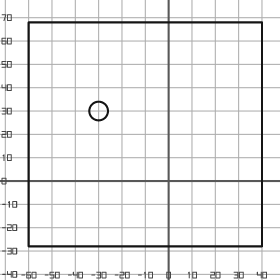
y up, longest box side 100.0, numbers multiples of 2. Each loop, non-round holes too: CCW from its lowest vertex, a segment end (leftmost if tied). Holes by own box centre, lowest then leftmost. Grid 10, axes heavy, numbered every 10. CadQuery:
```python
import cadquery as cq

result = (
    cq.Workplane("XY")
    .moveTo(-60.0, -28.0)
    .lineTo(40.0, -28.0)
    .lineTo(40.0, 68.0)
    .lineTo(-60.0, 68.0)
    .close()
    .moveTo(-30.0, 30.0)
    .circle(4.0)
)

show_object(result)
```